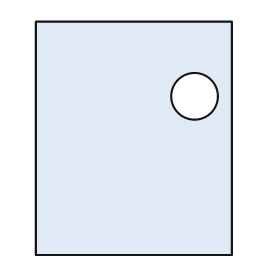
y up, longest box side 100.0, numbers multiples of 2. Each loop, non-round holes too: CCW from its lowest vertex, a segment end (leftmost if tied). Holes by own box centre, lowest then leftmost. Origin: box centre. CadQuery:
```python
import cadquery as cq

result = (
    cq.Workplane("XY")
    .moveTo(-42.0, -50.0)
    .lineTo(42.0, -50.0)
    .lineTo(42.0, 50.0)
    .lineTo(-42.0, 50.0)
    .close()
    .moveTo(26.0, 18.0)
    .circle(10.0)
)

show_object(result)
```